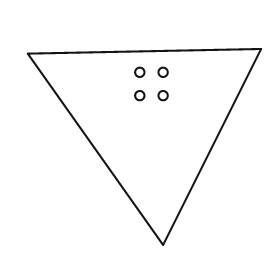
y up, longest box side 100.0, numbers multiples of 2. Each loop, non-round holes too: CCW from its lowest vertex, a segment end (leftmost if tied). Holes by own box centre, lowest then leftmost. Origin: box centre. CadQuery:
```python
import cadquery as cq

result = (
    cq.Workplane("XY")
    .moveTo(8.0, -42.0)
    .lineTo(50.0, 42.0)
    .lineTo(-50.0, 40.0)
    .close()
    .moveTo(-2.0, 22.0)
    .circle(2.0)
    .moveTo(8.0, 22.0)
    .circle(2.0)
    .moveTo(-2.0, 32.0)
    .circle(2.0)
    .moveTo(8.0, 32.0)
    .circle(2.0)
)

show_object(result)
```